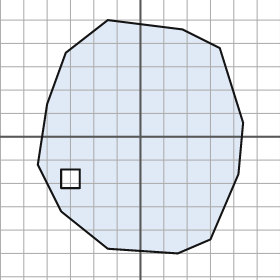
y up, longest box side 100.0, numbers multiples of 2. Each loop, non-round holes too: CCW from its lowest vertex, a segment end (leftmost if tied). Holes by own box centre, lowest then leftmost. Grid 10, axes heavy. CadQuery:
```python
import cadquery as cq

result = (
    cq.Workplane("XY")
    .moveTo(16.0, -50.0)
    .lineTo(30.0, -44.0)
    .lineTo(42.0, -16.0)
    .lineTo(44.0, 6.0)
    .lineTo(34.0, 38.0)
    .lineTo(18.0, 46.0)
    .lineTo(-14.0, 50.0)
    .lineTo(-32.0, 36.0)
    .lineTo(-40.0, 14.0)
    .lineTo(-44.0, -12.0)
    .lineTo(-34.0, -32.0)
    .lineTo(-14.0, -48.0)
    .close()
    .moveTo(-34.0, -22.0)
    .lineTo(-26.0, -22.0)
    .lineTo(-26.0, -14.0)
    .lineTo(-34.0, -14.0)
    .close()
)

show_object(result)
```